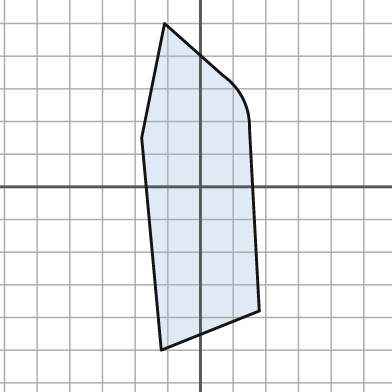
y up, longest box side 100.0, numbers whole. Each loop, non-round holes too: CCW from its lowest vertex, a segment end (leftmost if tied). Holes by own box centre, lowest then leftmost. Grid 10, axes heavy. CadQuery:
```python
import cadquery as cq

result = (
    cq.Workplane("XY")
    .moveTo(-12.0, -50.0)
    .lineTo(18.0, -38.0)
    .lineTo(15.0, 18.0)
    .threePointArc((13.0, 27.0), (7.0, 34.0))
    .lineTo(-11.0, 50.0)
    .lineTo(-18.0, 15.0)
    .close()
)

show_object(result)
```